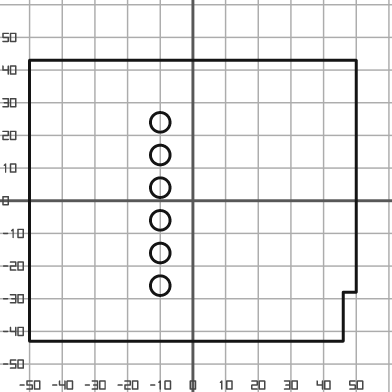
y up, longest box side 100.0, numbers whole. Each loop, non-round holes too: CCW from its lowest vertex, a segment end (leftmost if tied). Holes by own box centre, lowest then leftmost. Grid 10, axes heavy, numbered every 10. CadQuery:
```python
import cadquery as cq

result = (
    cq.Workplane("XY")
    .moveTo(-50.0, -43.0)
    .lineTo(46.0, -43.0)
    .lineTo(46.0, -28.0)
    .lineTo(50.0, -28.0)
    .lineTo(50.0, 43.0)
    .lineTo(-50.0, 43.0)
    .close()
    .moveTo(-10.0, -26.0)
    .circle(3.0)
    .moveTo(-10.0, -16.0)
    .circle(3.0)
    .moveTo(-10.0, -6.0)
    .circle(3.0)
    .moveTo(-10.0, 4.0)
    .circle(3.0)
    .moveTo(-10.0, 14.0)
    .circle(3.0)
    .moveTo(-10.0, 24.0)
    .circle(3.0)
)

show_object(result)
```